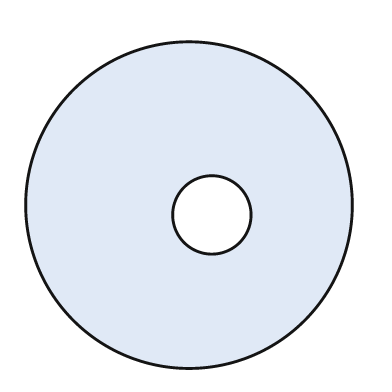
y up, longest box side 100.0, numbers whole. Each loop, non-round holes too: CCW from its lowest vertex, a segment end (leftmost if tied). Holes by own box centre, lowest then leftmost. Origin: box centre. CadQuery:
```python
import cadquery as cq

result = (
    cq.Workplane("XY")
    .moveTo(0.0, 0.0)
    .circle(50.0)
    .moveTo(7.0, -3.0)
    .circle(12.0)
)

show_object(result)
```